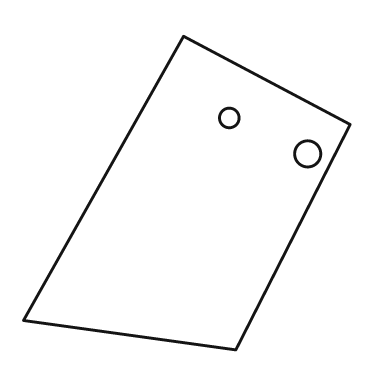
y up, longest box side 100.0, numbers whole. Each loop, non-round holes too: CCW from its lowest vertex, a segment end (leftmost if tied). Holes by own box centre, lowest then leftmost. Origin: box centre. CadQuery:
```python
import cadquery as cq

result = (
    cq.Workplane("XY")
    .moveTo(15.0, -48.0)
    .lineTo(50.0, 21.0)
    .lineTo(-1.0, 48.0)
    .lineTo(-50.0, -39.0)
    .close()
    .moveTo(37.0, 12.0)
    .circle(4.0)
    .moveTo(13.0, 23.0)
    .circle(3.0)
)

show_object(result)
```